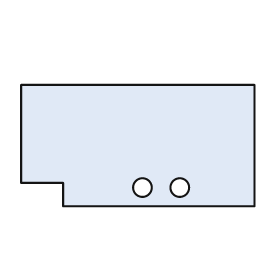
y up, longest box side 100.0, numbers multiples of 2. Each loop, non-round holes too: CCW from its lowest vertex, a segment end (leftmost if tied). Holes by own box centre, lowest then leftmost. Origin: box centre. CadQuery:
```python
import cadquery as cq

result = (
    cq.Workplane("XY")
    .moveTo(-32.0, -26.0)
    .lineTo(50.0, -26.0)
    .lineTo(50.0, 26.0)
    .lineTo(-50.0, 26.0)
    .lineTo(-50.0, -16.0)
    .lineTo(-32.0, -16.0)
    .close()
    .moveTo(2.0, -18.0)
    .circle(4.0)
    .moveTo(18.0, -18.0)
    .circle(4.0)
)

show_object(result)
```